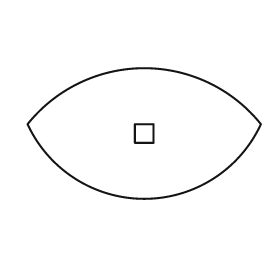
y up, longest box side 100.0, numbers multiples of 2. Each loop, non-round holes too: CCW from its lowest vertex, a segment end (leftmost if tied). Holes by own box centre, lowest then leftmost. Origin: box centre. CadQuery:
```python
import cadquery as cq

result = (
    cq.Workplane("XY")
    .moveTo(-50.0, 4.0)
    .threePointArc((0.0, -28.0), (50.0, 4.0))
    .threePointArc((0.0, 28.0), (-50.0, 4.0))
    .close()
    .moveTo(-4.0, -4.0)
    .lineTo(4.0, -4.0)
    .lineTo(4.0, 4.0)
    .lineTo(-4.0, 4.0)
    .close()
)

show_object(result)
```